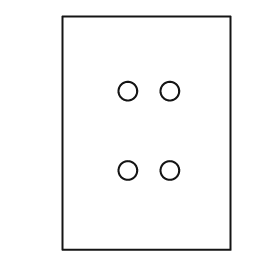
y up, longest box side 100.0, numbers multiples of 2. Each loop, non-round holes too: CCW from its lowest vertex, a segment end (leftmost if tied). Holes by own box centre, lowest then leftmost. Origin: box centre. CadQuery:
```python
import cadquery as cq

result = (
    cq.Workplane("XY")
    .moveTo(-36.0, -50.0)
    .lineTo(36.0, -50.0)
    .lineTo(36.0, 50.0)
    .lineTo(-36.0, 50.0)
    .close()
    .moveTo(-8.0, -16.0)
    .circle(4.0)
    .moveTo(10.0, -16.0)
    .circle(4.0)
    .moveTo(-8.0, 18.0)
    .circle(4.0)
    .moveTo(10.0, 18.0)
    .circle(4.0)
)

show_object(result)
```